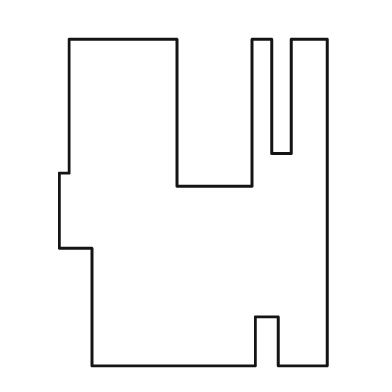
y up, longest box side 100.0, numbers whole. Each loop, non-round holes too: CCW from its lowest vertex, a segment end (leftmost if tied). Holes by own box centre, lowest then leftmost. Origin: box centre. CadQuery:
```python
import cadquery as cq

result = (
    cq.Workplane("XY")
    .moveTo(-31.0, -50.0)
    .lineTo(19.0, -50.0)
    .lineTo(19.0, -35.0)
    .lineTo(26.0, -35.0)
    .lineTo(26.0, -50.0)
    .lineTo(41.0, -50.0)
    .lineTo(41.0, 50.0)
    .lineTo(30.0, 50.0)
    .lineTo(30.0, 15.0)
    .lineTo(24.0, 15.0)
    .lineTo(24.0, 50.0)
    .lineTo(18.0, 50.0)
    .lineTo(18.0, 5.0)
    .lineTo(-5.0, 5.0)
    .lineTo(-5.0, 50.0)
    .lineTo(-38.0, 50.0)
    .lineTo(-38.0, 9.0)
    .lineTo(-41.0, 9.0)
    .lineTo(-41.0, -14.0)
    .lineTo(-31.0, -14.0)
    .close()
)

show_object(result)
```